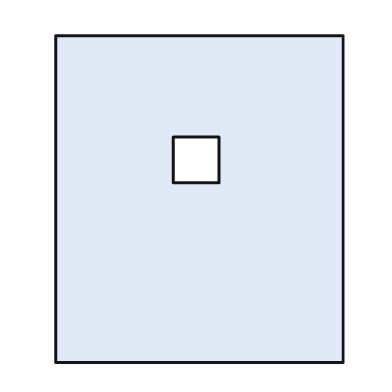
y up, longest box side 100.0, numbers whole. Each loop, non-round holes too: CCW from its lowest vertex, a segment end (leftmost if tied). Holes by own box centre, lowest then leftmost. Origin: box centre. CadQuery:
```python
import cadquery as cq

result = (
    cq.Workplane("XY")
    .moveTo(-44.0, -50.0)
    .lineTo(44.0, -50.0)
    .lineTo(44.0, 50.0)
    .lineTo(-44.0, 50.0)
    .close()
    .moveTo(-8.0, 5.0)
    .lineTo(6.0, 5.0)
    .lineTo(6.0, 19.0)
    .lineTo(-8.0, 19.0)
    .close()
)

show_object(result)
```